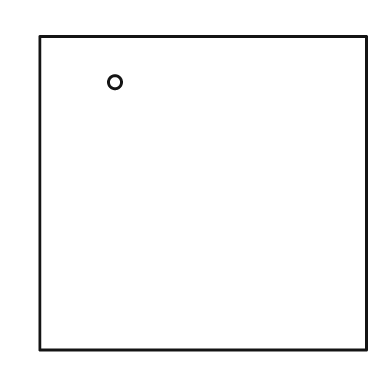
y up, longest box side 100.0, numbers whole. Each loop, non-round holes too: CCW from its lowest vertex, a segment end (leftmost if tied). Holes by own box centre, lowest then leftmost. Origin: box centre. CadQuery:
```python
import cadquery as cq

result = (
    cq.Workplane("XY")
    .moveTo(-50.0, -48.0)
    .lineTo(50.0, -48.0)
    .lineTo(50.0, 48.0)
    .lineTo(-50.0, 48.0)
    .close()
    .moveTo(-27.0, 34.0)
    .circle(2.0)
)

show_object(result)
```